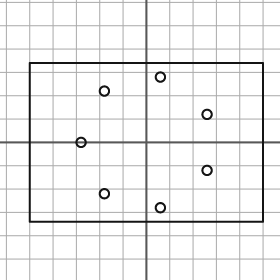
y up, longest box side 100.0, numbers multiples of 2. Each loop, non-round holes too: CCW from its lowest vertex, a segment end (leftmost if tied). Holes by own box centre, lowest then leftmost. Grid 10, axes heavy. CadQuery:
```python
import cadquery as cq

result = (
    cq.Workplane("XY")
    .moveTo(-50.0, -34.0)
    .lineTo(50.0, -34.0)
    .lineTo(50.0, 34.0)
    .lineTo(-50.0, 34.0)
    .close()
    .moveTo(6.0, -28.0)
    .circle(2.0)
    .moveTo(-18.0, -22.0)
    .circle(2.0)
    .moveTo(26.0, -12.0)
    .circle(2.0)
    .moveTo(-28.0, 0.0)
    .circle(2.0)
    .moveTo(26.0, 12.0)
    .circle(2.0)
    .moveTo(-18.0, 22.0)
    .circle(2.0)
    .moveTo(6.0, 28.0)
    .circle(2.0)
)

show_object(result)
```